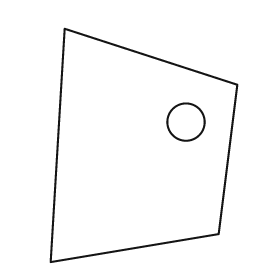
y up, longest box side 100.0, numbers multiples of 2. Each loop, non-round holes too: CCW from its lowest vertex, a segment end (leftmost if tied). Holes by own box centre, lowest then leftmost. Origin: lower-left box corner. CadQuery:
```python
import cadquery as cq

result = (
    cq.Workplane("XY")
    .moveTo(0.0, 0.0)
    .lineTo(72.0, 12.0)
    .lineTo(80.0, 76.0)
    .lineTo(6.0, 100.0)
    .close()
    .moveTo(58.0, 60.0)
    .circle(8.0)
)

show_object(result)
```